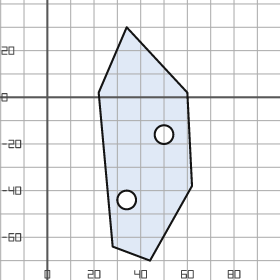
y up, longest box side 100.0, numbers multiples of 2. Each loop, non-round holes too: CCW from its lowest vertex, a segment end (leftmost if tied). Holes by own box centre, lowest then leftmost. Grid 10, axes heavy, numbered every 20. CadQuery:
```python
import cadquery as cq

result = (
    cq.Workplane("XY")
    .moveTo(44.0, -70.0)
    .lineTo(62.0, -38.0)
    .lineTo(60.0, 2.0)
    .lineTo(34.0, 30.0)
    .lineTo(22.0, 2.0)
    .lineTo(28.0, -64.0)
    .close()
    .moveTo(34.0, -44.0)
    .circle(4.0)
    .moveTo(50.0, -16.0)
    .circle(4.0)
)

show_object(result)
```